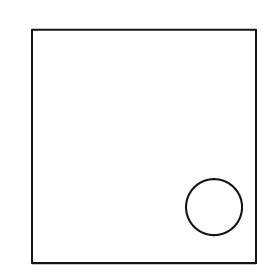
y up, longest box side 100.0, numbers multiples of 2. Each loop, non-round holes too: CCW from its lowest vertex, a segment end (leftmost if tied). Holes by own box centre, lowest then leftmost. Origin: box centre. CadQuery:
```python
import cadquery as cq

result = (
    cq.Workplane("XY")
    .moveTo(-48.0, -50.0)
    .lineTo(48.0, -50.0)
    .lineTo(48.0, 50.0)
    .lineTo(-48.0, 50.0)
    .close()
    .moveTo(30.0, -26.0)
    .circle(12.0)
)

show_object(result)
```